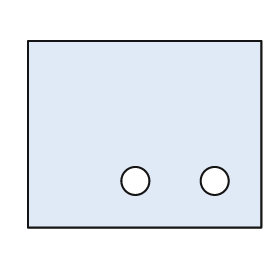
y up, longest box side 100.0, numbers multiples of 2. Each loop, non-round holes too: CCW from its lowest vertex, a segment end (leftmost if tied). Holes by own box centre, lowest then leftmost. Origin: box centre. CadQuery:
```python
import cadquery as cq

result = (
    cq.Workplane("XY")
    .moveTo(-50.0, -40.0)
    .lineTo(50.0, -40.0)
    .lineTo(50.0, 40.0)
    .lineTo(-50.0, 40.0)
    .close()
    .moveTo(-4.0, -20.0)
    .circle(6.0)
    .moveTo(30.0, -20.0)
    .circle(6.0)
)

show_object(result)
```